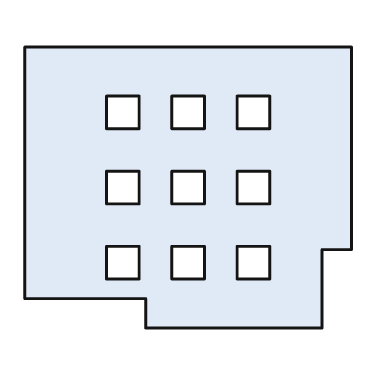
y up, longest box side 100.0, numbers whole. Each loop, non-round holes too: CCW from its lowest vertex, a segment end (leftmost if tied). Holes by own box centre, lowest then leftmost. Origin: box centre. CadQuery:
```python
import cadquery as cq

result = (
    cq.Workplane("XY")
    .moveTo(-13.0, -43.0)
    .lineTo(41.0, -43.0)
    .lineTo(41.0, -19.0)
    .lineTo(50.0, -19.0)
    .lineTo(50.0, 43.0)
    .lineTo(-50.0, 43.0)
    .lineTo(-50.0, -34.0)
    .lineTo(-13.0, -34.0)
    .close()
    .moveTo(-25.0, -28.0)
    .lineTo(-15.0, -28.0)
    .lineTo(-15.0, -18.0)
    .lineTo(-25.0, -18.0)
    .close()
    .moveTo(-5.0, -28.0)
    .lineTo(5.0, -28.0)
    .lineTo(5.0, -18.0)
    .lineTo(-5.0, -18.0)
    .close()
    .moveTo(15.0, -28.0)
    .lineTo(25.0, -28.0)
    .lineTo(25.0, -18.0)
    .lineTo(15.0, -18.0)
    .close()
    .moveTo(-25.0, -5.0)
    .lineTo(-15.0, -5.0)
    .lineTo(-15.0, 5.0)
    .lineTo(-25.0, 5.0)
    .close()
    .moveTo(-5.0, -5.0)
    .lineTo(5.0, -5.0)
    .lineTo(5.0, 5.0)
    .lineTo(-5.0, 5.0)
    .close()
    .moveTo(15.0, -5.0)
    .lineTo(25.0, -5.0)
    .lineTo(25.0, 5.0)
    .lineTo(15.0, 5.0)
    .close()
    .moveTo(-25.0, 18.0)
    .lineTo(-15.0, 18.0)
    .lineTo(-15.0, 28.0)
    .lineTo(-25.0, 28.0)
    .close()
    .moveTo(-5.0, 18.0)
    .lineTo(5.0, 18.0)
    .lineTo(5.0, 28.0)
    .lineTo(-5.0, 28.0)
    .close()
    .moveTo(15.0, 18.0)
    .lineTo(25.0, 18.0)
    .lineTo(25.0, 28.0)
    .lineTo(15.0, 28.0)
    .close()
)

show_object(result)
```